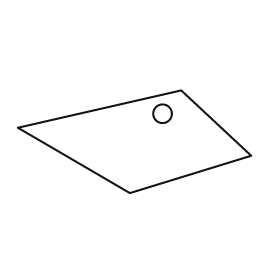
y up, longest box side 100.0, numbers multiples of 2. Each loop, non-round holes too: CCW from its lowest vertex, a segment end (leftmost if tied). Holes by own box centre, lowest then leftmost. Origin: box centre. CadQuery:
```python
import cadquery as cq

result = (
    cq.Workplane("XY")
    .moveTo(-2.0, -22.0)
    .lineTo(50.0, -6.0)
    .lineTo(20.0, 22.0)
    .lineTo(-50.0, 6.0)
    .close()
    .moveTo(12.0, 12.0)
    .circle(4.0)
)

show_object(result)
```